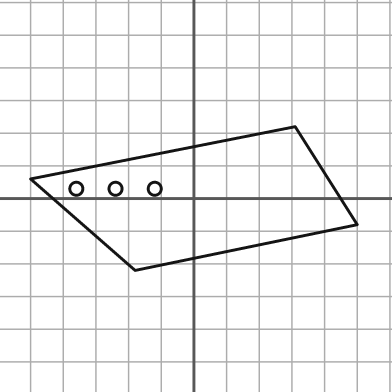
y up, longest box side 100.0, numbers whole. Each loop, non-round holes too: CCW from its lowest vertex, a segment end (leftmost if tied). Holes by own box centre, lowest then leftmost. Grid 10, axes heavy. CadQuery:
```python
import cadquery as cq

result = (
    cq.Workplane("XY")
    .moveTo(-18.0, -22.0)
    .lineTo(50.0, -8.0)
    .lineTo(31.0, 22.0)
    .lineTo(-50.0, 6.0)
    .close()
    .moveTo(-36.0, 3.0)
    .circle(2.0)
    .moveTo(-24.0, 3.0)
    .circle(2.0)
    .moveTo(-12.0, 3.0)
    .circle(2.0)
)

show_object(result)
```